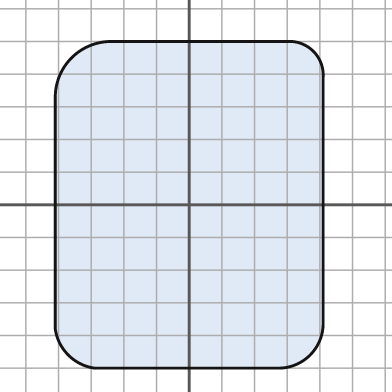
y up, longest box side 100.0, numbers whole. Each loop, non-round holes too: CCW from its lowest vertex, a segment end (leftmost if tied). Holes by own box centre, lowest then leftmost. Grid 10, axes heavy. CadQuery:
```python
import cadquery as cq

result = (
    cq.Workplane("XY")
    .moveTo(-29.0, -50.0)
    .lineTo(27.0, -50.0)
    .threePointArc((37.0, -46.0), (41.0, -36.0))
    .lineTo(41.0, 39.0)
    .threePointArc((38.0, 47.0), (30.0, 50.0))
    .lineTo(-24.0, 50.0)
    .threePointArc((-36.0, 45.0), (-41.0, 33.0))
    .lineTo(-41.0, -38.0)
    .threePointArc((-37.0, -46.0), (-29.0, -50.0))
    .close()
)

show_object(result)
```